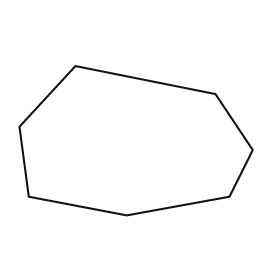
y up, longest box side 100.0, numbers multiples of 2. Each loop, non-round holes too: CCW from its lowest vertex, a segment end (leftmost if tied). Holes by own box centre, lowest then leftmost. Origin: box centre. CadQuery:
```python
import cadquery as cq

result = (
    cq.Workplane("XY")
    .moveTo(-4.0, -32.0)
    .lineTo(40.0, -24.0)
    .lineTo(50.0, -4.0)
    .lineTo(34.0, 20.0)
    .lineTo(-26.0, 32.0)
    .lineTo(-50.0, 6.0)
    .lineTo(-46.0, -24.0)
    .close()
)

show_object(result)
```